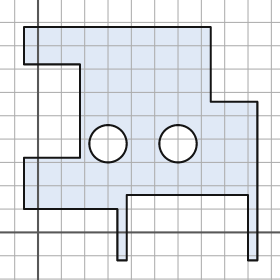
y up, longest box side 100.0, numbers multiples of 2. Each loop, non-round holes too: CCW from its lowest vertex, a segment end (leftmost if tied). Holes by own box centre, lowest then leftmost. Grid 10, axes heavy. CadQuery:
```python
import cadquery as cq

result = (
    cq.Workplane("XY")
    .moveTo(34.0, -12.0)
    .lineTo(38.0, -12.0)
    .lineTo(38.0, 16.0)
    .lineTo(90.0, 16.0)
    .lineTo(90.0, -12.0)
    .lineTo(94.0, -12.0)
    .lineTo(94.0, 56.0)
    .lineTo(74.0, 56.0)
    .lineTo(74.0, 88.0)
    .lineTo(-6.0, 88.0)
    .lineTo(-6.0, 72.0)
    .lineTo(18.0, 72.0)
    .lineTo(18.0, 32.0)
    .lineTo(-6.0, 32.0)
    .lineTo(-6.0, 10.0)
    .lineTo(34.0, 10.0)
    .close()
    .moveTo(30.0, 38.0)
    .circle(8.0)
    .moveTo(60.0, 38.0)
    .circle(8.0)
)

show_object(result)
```